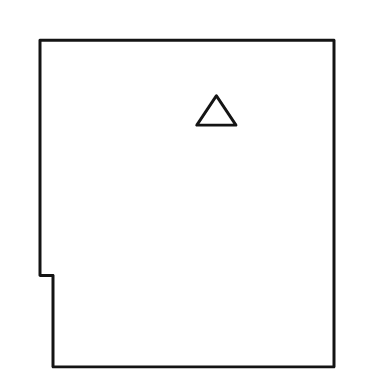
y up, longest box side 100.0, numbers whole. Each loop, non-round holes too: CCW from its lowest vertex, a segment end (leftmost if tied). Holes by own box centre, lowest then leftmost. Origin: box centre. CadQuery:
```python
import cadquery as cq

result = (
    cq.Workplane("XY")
    .moveTo(-41.0, -50.0)
    .lineTo(45.0, -50.0)
    .lineTo(45.0, 50.0)
    .lineTo(-45.0, 50.0)
    .lineTo(-45.0, -22.0)
    .lineTo(-41.0, -22.0)
    .close()
    .moveTo(3.0, 24.0)
    .lineTo(15.0, 24.0)
    .lineTo(9.0, 33.0)
    .close()
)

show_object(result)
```